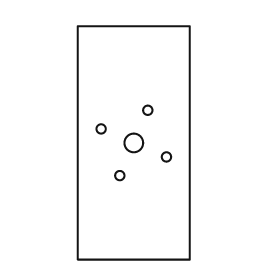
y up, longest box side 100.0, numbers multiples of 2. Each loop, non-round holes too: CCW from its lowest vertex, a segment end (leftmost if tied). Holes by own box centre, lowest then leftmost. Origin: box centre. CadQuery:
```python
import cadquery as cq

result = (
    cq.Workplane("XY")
    .moveTo(-24.0, -50.0)
    .lineTo(24.0, -50.0)
    .lineTo(24.0, 50.0)
    .lineTo(-24.0, 50.0)
    .close()
    .moveTo(-6.0, -14.0)
    .circle(2.0)
    .moveTo(14.0, -6.0)
    .circle(2.0)
    .moveTo(0.0, 0.0)
    .circle(4.0)
    .moveTo(-14.0, 6.0)
    .circle(2.0)
    .moveTo(6.0, 14.0)
    .circle(2.0)
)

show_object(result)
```